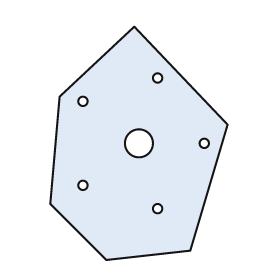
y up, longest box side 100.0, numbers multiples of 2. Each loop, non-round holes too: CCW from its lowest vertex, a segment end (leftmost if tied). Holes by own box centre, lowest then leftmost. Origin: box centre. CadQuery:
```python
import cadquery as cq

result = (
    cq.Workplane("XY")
    .moveTo(-14.0, -50.0)
    .lineTo(22.0, -46.0)
    .lineTo(38.0, 8.0)
    .lineTo(-2.0, 50.0)
    .lineTo(-34.0, 20.0)
    .lineTo(-38.0, -26.0)
    .close()
    .moveTo(8.0, -28.0)
    .circle(2.0)
    .moveTo(-24.0, -18.0)
    .circle(2.0)
    .moveTo(0.0, 0.0)
    .circle(6.0)
    .moveTo(28.0, 0.0)
    .circle(2.0)
    .moveTo(-24.0, 18.0)
    .circle(2.0)
    .moveTo(8.0, 28.0)
    .circle(2.0)
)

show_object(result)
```